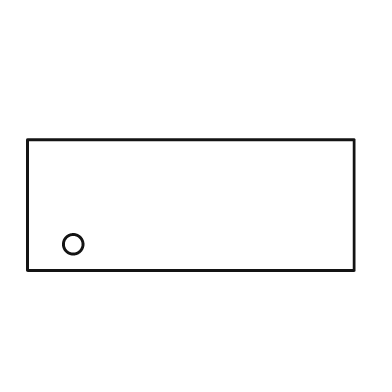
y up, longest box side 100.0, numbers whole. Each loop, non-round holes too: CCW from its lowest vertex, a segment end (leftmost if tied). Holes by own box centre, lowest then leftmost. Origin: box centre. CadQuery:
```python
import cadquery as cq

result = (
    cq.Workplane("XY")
    .moveTo(-50.0, -20.0)
    .lineTo(50.0, -20.0)
    .lineTo(50.0, 20.0)
    .lineTo(-50.0, 20.0)
    .close()
    .moveTo(-36.0, -12.0)
    .circle(3.0)
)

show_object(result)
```